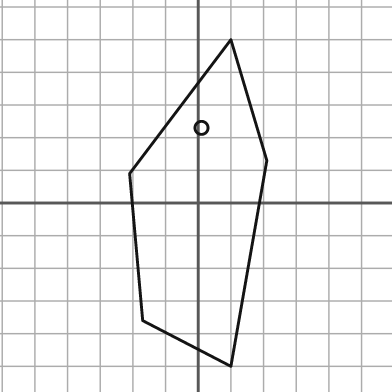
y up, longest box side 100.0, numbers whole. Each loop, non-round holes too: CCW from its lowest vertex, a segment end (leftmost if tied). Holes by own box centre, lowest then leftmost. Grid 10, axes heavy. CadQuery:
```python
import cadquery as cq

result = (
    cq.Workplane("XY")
    .moveTo(10.0, -50.0)
    .lineTo(21.0, 13.0)
    .lineTo(10.0, 50.0)
    .lineTo(-21.0, 9.0)
    .lineTo(-17.0, -36.0)
    .close()
    .moveTo(1.0, 23.0)
    .circle(2.0)
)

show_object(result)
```